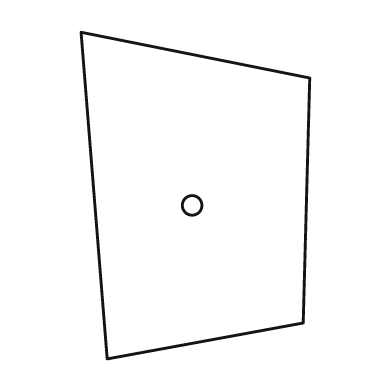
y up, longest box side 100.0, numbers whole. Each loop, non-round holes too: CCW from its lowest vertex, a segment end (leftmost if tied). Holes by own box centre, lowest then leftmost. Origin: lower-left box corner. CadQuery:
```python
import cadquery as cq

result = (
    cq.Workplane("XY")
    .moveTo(8.0, 0.0)
    .lineTo(68.0, 11.0)
    .lineTo(70.0, 86.0)
    .lineTo(0.0, 100.0)
    .close()
    .moveTo(34.0, 47.0)
    .circle(3.0)
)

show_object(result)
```